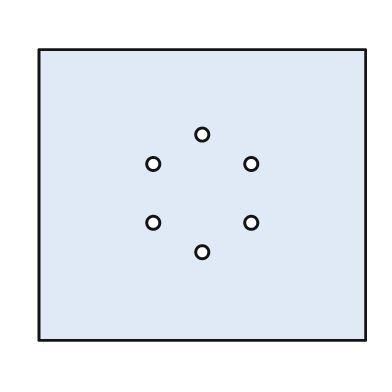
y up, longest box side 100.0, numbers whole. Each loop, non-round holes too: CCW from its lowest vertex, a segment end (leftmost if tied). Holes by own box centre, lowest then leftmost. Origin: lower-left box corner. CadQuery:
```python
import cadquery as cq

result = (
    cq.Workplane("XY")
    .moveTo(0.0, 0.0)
    .lineTo(100.0, 0.0)
    .lineTo(100.0, 89.0)
    .lineTo(0.0, 89.0)
    .close()
    .moveTo(50.0, 27.0)
    .circle(2.0)
    .moveTo(35.0, 36.0)
    .circle(2.0)
    .moveTo(65.0, 36.0)
    .circle(2.0)
    .moveTo(35.0, 54.0)
    .circle(2.0)
    .moveTo(65.0, 54.0)
    .circle(2.0)
    .moveTo(50.0, 63.0)
    .circle(2.0)
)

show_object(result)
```